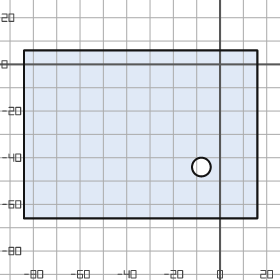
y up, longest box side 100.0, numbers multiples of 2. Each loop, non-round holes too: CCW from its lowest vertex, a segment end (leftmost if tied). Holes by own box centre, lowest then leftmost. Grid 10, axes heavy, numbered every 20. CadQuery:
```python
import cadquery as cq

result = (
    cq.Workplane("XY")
    .moveTo(-84.0, -66.0)
    .lineTo(16.0, -66.0)
    .lineTo(16.0, 6.0)
    .lineTo(-84.0, 6.0)
    .close()
    .moveTo(-8.0, -44.0)
    .circle(4.0)
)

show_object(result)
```